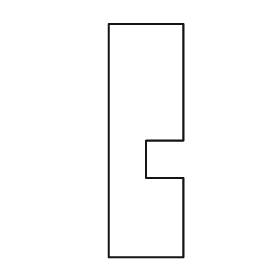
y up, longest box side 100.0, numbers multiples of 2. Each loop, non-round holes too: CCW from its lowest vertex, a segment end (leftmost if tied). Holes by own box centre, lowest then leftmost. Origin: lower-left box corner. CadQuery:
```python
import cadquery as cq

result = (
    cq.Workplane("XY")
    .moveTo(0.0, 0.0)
    .lineTo(32.0, 0.0)
    .lineTo(32.0, 34.0)
    .lineTo(16.0, 34.0)
    .lineTo(16.0, 50.0)
    .lineTo(32.0, 50.0)
    .lineTo(32.0, 100.0)
    .lineTo(0.0, 100.0)
    .close()
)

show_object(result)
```